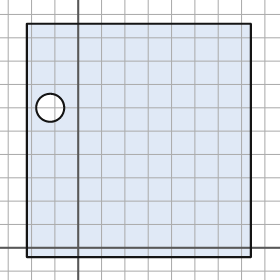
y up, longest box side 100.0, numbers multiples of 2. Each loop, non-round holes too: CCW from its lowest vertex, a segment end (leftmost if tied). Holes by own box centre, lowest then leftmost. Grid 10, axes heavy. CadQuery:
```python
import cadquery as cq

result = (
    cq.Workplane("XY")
    .moveTo(-22.0, -4.0)
    .lineTo(74.0, -4.0)
    .lineTo(74.0, 96.0)
    .lineTo(-22.0, 96.0)
    .close()
    .moveTo(-12.0, 60.0)
    .circle(6.0)
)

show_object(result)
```